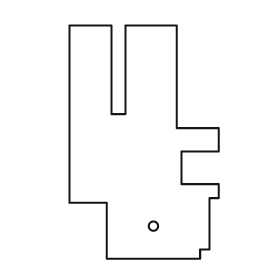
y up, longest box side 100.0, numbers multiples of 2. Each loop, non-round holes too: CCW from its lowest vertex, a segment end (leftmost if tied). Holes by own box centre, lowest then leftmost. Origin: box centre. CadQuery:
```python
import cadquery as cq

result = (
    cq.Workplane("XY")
    .moveTo(-16.0, -50.0)
    .lineTo(24.0, -50.0)
    .lineTo(24.0, -46.0)
    .lineTo(28.0, -46.0)
    .lineTo(28.0, -24.0)
    .lineTo(32.0, -24.0)
    .lineTo(32.0, -18.0)
    .lineTo(16.0, -18.0)
    .lineTo(16.0, -4.0)
    .lineTo(32.0, -4.0)
    .lineTo(32.0, 6.0)
    .lineTo(14.0, 6.0)
    .lineTo(14.0, 50.0)
    .lineTo(-8.0, 50.0)
    .lineTo(-8.0, 12.0)
    .lineTo(-14.0, 12.0)
    .lineTo(-14.0, 50.0)
    .lineTo(-32.0, 50.0)
    .lineTo(-32.0, -26.0)
    .lineTo(-16.0, -26.0)
    .close()
    .moveTo(4.0, -36.0)
    .circle(2.0)
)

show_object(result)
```